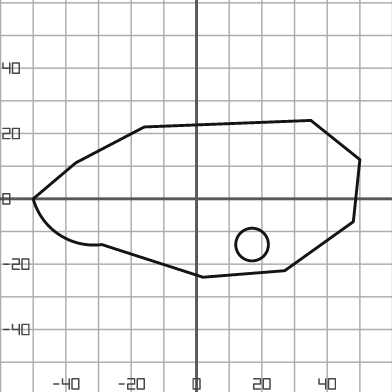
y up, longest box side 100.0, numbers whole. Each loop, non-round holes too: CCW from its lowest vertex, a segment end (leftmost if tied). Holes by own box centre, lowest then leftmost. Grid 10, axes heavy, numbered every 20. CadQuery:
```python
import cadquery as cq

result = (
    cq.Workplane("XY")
    .moveTo(2.0, -24.0)
    .lineTo(27.0, -22.0)
    .lineTo(48.0, -7.0)
    .lineTo(50.0, 12.0)
    .lineTo(35.0, 24.0)
    .lineTo(-16.0, 22.0)
    .lineTo(-37.0, 11.0)
    .lineTo(-50.0, 0.0)
    .threePointArc((-42.0, -11.0), (-29.0, -14.0))
    .close()
    .moveTo(17.0, -14.0)
    .circle(5.0)
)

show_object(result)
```